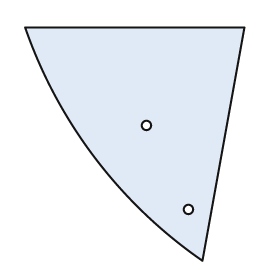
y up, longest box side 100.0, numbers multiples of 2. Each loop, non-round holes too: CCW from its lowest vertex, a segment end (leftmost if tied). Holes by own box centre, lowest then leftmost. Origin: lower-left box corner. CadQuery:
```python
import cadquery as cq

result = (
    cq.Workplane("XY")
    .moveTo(76.0, 0.0)
    .lineTo(94.0, 100.0)
    .lineTo(0.0, 100.0)
    .threePointArc((30.0, 44.0), (76.0, 0.0))
    .close()
    .moveTo(70.0, 22.0)
    .circle(2.0)
    .moveTo(52.0, 58.0)
    .circle(2.0)
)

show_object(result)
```